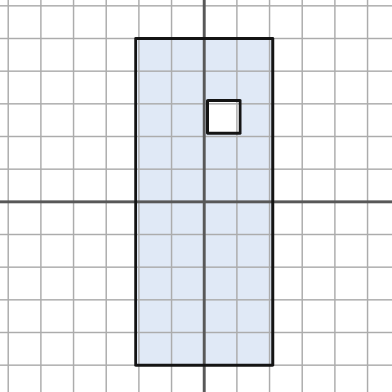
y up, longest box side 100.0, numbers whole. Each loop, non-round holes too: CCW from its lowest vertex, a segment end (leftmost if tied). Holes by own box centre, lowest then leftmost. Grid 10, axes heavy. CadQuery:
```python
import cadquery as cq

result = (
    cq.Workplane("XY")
    .moveTo(-21.0, -50.0)
    .lineTo(21.0, -50.0)
    .lineTo(21.0, 50.0)
    .lineTo(-21.0, 50.0)
    .close()
    .moveTo(1.0, 21.0)
    .lineTo(11.0, 21.0)
    .lineTo(11.0, 31.0)
    .lineTo(1.0, 31.0)
    .close()
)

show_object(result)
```